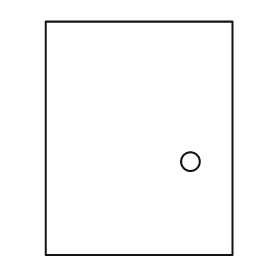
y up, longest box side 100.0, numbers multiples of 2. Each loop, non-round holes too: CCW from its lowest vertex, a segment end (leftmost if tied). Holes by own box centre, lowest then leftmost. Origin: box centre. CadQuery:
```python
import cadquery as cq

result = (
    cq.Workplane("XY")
    .moveTo(-40.0, -50.0)
    .lineTo(40.0, -50.0)
    .lineTo(40.0, 50.0)
    .lineTo(-40.0, 50.0)
    .close()
    .moveTo(22.0, -10.0)
    .circle(4.0)
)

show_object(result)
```